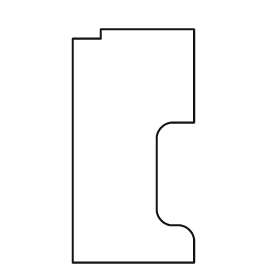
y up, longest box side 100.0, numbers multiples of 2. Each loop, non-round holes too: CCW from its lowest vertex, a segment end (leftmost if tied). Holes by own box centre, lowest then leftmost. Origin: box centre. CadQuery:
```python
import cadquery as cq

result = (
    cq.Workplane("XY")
    .moveTo(-26.0, -50.0)
    .lineTo(26.0, -50.0)
    .lineTo(26.0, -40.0)
    .threePointArc((24.0, -36.0), (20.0, -34.0))
    .lineTo(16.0, -34.0)
    .threePointArc((12.0, -32.0), (10.0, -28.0))
    .lineTo(10.0, 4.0)
    .threePointArc((12.0, 8.0), (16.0, 10.0))
    .lineTo(26.0, 10.0)
    .lineTo(26.0, 50.0)
    .lineTo(-14.0, 50.0)
    .lineTo(-14.0, 46.0)
    .lineTo(-26.0, 46.0)
    .close()
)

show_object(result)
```